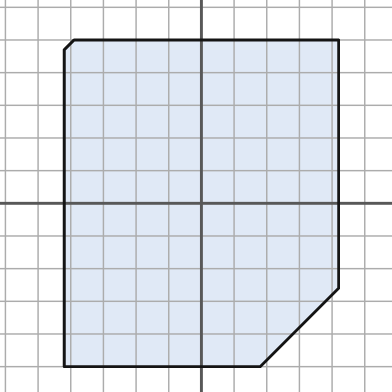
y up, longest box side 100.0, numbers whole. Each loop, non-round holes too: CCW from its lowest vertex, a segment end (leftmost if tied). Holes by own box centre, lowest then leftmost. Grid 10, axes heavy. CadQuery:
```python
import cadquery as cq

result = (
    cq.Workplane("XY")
    .moveTo(-42.0, -50.0)
    .lineTo(18.0, -50.0)
    .lineTo(42.0, -26.0)
    .lineTo(42.0, 50.0)
    .lineTo(-39.0, 50.0)
    .lineTo(-42.0, 47.0)
    .close()
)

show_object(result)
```